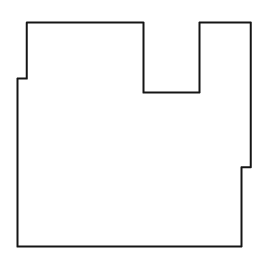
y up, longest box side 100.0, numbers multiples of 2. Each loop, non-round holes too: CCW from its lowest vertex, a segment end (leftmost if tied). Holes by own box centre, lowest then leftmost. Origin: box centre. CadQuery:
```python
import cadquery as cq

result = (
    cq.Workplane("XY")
    .moveTo(-50.0, -48.0)
    .lineTo(46.0, -48.0)
    .lineTo(46.0, -14.0)
    .lineTo(50.0, -14.0)
    .lineTo(50.0, 48.0)
    .lineTo(28.0, 48.0)
    .lineTo(28.0, 18.0)
    .lineTo(4.0, 18.0)
    .lineTo(4.0, 48.0)
    .lineTo(-46.0, 48.0)
    .lineTo(-46.0, 24.0)
    .lineTo(-50.0, 24.0)
    .close()
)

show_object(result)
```